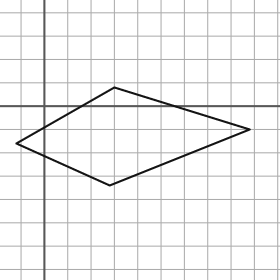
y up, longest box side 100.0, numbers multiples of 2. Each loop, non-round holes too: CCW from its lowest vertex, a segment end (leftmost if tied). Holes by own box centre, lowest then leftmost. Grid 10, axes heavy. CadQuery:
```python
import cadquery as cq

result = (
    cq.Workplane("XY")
    .moveTo(28.0, -34.0)
    .lineTo(88.0, -10.0)
    .lineTo(30.0, 8.0)
    .lineTo(-12.0, -16.0)
    .close()
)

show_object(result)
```